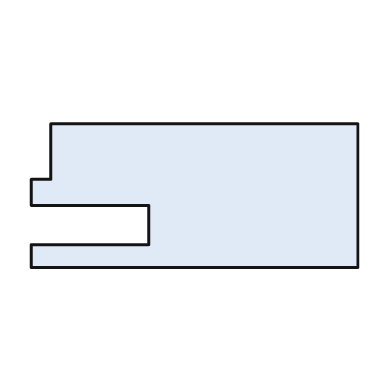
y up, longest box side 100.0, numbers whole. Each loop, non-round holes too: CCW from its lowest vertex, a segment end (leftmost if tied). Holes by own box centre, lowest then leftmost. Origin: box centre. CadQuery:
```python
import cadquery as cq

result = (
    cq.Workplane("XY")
    .moveTo(-50.0, -22.0)
    .lineTo(50.0, -22.0)
    .lineTo(50.0, 22.0)
    .lineTo(-44.0, 22.0)
    .lineTo(-44.0, 5.0)
    .lineTo(-50.0, 5.0)
    .lineTo(-50.0, -3.0)
    .lineTo(-14.0, -3.0)
    .lineTo(-14.0, -15.0)
    .lineTo(-50.0, -15.0)
    .close()
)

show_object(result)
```